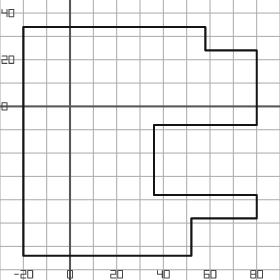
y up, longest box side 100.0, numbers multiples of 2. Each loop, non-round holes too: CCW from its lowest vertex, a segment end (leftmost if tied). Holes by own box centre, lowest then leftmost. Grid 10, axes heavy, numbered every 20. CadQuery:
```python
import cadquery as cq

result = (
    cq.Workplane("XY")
    .moveTo(-20.0, -64.0)
    .lineTo(52.0, -64.0)
    .lineTo(52.0, -48.0)
    .lineTo(80.0, -48.0)
    .lineTo(80.0, -38.0)
    .lineTo(36.0, -38.0)
    .lineTo(36.0, -8.0)
    .lineTo(80.0, -8.0)
    .lineTo(80.0, 24.0)
    .lineTo(58.0, 24.0)
    .lineTo(58.0, 34.0)
    .lineTo(-20.0, 34.0)
    .close()
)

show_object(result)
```